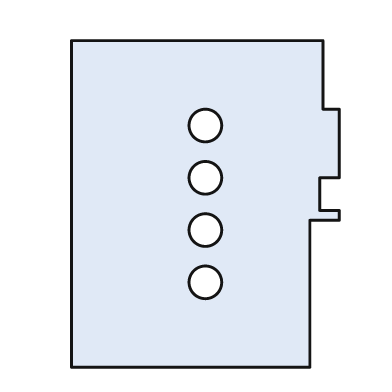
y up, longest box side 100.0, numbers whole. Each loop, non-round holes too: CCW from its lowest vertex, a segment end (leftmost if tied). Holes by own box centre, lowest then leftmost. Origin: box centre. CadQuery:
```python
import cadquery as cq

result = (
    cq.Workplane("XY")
    .moveTo(-41.0, -50.0)
    .lineTo(32.0, -50.0)
    .lineTo(32.0, -5.0)
    .lineTo(41.0, -5.0)
    .lineTo(41.0, -2.0)
    .lineTo(35.0, -2.0)
    .lineTo(35.0, 8.0)
    .lineTo(41.0, 8.0)
    .lineTo(41.0, 29.0)
    .lineTo(36.0, 29.0)
    .lineTo(36.0, 50.0)
    .lineTo(-41.0, 50.0)
    .close()
    .moveTo(0.0, -24.0)
    .circle(5.0)
    .moveTo(0.0, -8.0)
    .circle(5.0)
    .moveTo(0.0, 8.0)
    .circle(5.0)
    .moveTo(0.0, 24.0)
    .circle(5.0)
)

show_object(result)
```